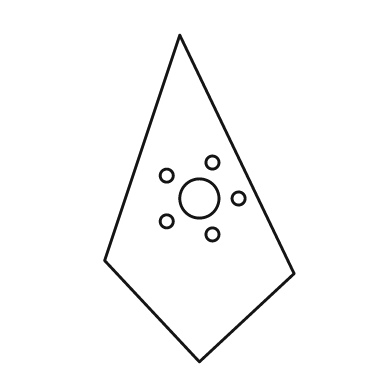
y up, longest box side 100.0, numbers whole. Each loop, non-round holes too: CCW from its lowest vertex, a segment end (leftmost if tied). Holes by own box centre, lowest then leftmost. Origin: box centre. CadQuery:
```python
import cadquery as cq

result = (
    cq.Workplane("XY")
    .moveTo(0.0, -50.0)
    .lineTo(29.0, -23.0)
    .lineTo(-6.0, 50.0)
    .lineTo(-29.0, -19.0)
    .close()
    .moveTo(4.0, -11.0)
    .circle(2.0)
    .moveTo(-10.0, -7.0)
    .circle(2.0)
    .moveTo(0.0, 0.0)
    .circle(6.0)
    .moveTo(12.0, 0.0)
    .circle(2.0)
    .moveTo(-10.0, 7.0)
    .circle(2.0)
    .moveTo(4.0, 11.0)
    .circle(2.0)
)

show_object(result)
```